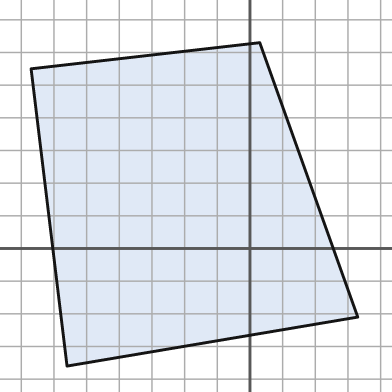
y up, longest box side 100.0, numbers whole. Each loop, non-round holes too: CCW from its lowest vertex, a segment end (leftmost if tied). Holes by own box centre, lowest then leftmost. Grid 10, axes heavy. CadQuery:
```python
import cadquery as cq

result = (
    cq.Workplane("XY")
    .moveTo(-56.0, -36.0)
    .lineTo(33.0, -21.0)
    .lineTo(3.0, 63.0)
    .lineTo(-67.0, 55.0)
    .close()
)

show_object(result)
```